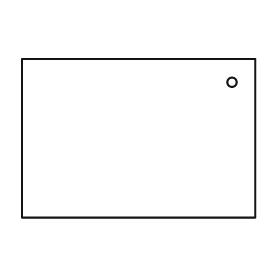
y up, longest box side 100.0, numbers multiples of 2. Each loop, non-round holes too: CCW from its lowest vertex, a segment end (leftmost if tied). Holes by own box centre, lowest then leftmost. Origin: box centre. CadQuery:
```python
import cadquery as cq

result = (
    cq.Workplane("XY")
    .moveTo(-50.0, -34.0)
    .lineTo(50.0, -34.0)
    .lineTo(50.0, 34.0)
    .lineTo(-50.0, 34.0)
    .close()
    .moveTo(40.0, 24.0)
    .circle(2.0)
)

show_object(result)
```